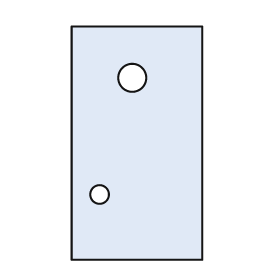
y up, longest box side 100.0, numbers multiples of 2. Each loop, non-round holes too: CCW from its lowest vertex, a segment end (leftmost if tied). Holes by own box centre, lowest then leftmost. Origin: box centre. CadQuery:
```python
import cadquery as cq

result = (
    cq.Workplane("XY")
    .moveTo(-28.0, -50.0)
    .lineTo(28.0, -50.0)
    .lineTo(28.0, 50.0)
    .lineTo(-28.0, 50.0)
    .close()
    .moveTo(-16.0, -22.0)
    .circle(4.0)
    .moveTo(-2.0, 28.0)
    .circle(6.0)
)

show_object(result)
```